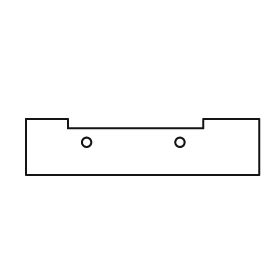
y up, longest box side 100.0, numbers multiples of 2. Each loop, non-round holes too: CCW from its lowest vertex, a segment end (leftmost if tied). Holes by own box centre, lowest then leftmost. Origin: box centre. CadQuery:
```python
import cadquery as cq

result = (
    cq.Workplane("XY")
    .moveTo(-50.0, -12.0)
    .lineTo(50.0, -12.0)
    .lineTo(50.0, 12.0)
    .lineTo(26.0, 12.0)
    .lineTo(26.0, 8.0)
    .lineTo(-32.0, 8.0)
    .lineTo(-32.0, 12.0)
    .lineTo(-50.0, 12.0)
    .close()
    .moveTo(-24.0, 2.0)
    .circle(2.0)
    .moveTo(16.0, 2.0)
    .circle(2.0)
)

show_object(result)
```